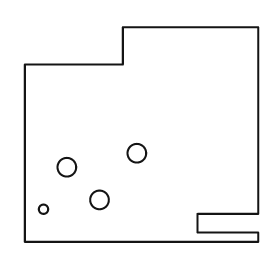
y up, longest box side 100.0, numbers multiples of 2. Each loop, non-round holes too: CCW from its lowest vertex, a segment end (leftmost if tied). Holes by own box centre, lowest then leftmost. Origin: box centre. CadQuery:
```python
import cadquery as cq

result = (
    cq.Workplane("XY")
    .moveTo(-50.0, -46.0)
    .lineTo(50.0, -46.0)
    .lineTo(50.0, -42.0)
    .lineTo(24.0, -42.0)
    .lineTo(24.0, -34.0)
    .lineTo(50.0, -34.0)
    .lineTo(50.0, 46.0)
    .lineTo(-8.0, 46.0)
    .lineTo(-8.0, 30.0)
    .lineTo(-50.0, 30.0)
    .close()
    .moveTo(-42.0, -32.0)
    .circle(2.0)
    .moveTo(-18.0, -28.0)
    .circle(4.0)
    .moveTo(-32.0, -14.0)
    .circle(4.0)
    .moveTo(-2.0, -8.0)
    .circle(4.0)
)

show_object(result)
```